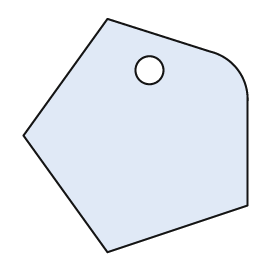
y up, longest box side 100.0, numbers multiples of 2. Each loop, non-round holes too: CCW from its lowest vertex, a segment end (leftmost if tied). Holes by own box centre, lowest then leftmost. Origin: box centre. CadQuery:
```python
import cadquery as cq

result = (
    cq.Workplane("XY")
    .moveTo(-12.0, -50.0)
    .lineTo(48.0, -30.0)
    .lineTo(48.0, 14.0)
    .threePointArc((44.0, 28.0), (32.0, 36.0))
    .lineTo(-12.0, 50.0)
    .lineTo(-48.0, 0.0)
    .close()
    .moveTo(6.0, 28.0)
    .circle(6.0)
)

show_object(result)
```